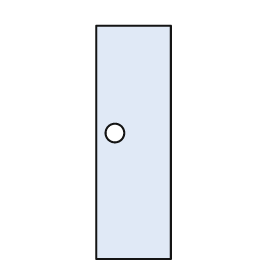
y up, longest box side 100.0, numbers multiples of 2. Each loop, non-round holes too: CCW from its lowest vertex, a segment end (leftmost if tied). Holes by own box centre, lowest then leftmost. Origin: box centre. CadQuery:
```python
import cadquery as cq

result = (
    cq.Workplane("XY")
    .moveTo(-16.0, -50.0)
    .lineTo(16.0, -50.0)
    .lineTo(16.0, 50.0)
    .lineTo(-16.0, 50.0)
    .close()
    .moveTo(-8.0, 4.0)
    .circle(4.0)
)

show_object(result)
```